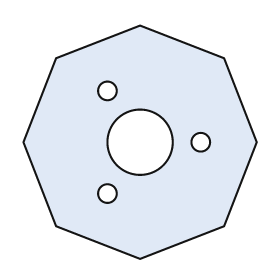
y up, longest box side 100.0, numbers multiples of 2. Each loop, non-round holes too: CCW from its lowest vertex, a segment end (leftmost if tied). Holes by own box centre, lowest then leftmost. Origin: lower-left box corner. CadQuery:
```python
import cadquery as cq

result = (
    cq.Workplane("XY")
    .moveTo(50.0, 0.0)
    .lineTo(86.0, 14.0)
    .lineTo(100.0, 50.0)
    .lineTo(86.0, 86.0)
    .lineTo(50.0, 100.0)
    .lineTo(14.0, 86.0)
    .lineTo(0.0, 50.0)
    .lineTo(14.0, 14.0)
    .close()
    .moveTo(36.0, 28.0)
    .circle(4.0)
    .moveTo(50.0, 50.0)
    .circle(14.0)
    .moveTo(76.0, 50.0)
    .circle(4.0)
    .moveTo(36.0, 72.0)
    .circle(4.0)
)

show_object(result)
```